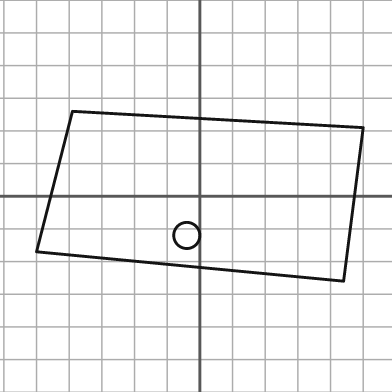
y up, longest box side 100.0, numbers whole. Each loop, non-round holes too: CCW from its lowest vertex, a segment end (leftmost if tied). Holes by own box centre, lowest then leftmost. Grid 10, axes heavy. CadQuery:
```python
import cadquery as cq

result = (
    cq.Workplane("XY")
    .moveTo(44.0, -26.0)
    .lineTo(50.0, 21.0)
    .lineTo(-39.0, 26.0)
    .lineTo(-50.0, -17.0)
    .close()
    .moveTo(-4.0, -12.0)
    .circle(4.0)
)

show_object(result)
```